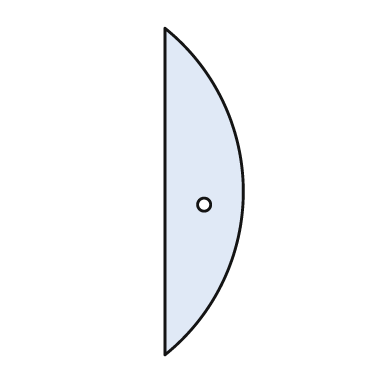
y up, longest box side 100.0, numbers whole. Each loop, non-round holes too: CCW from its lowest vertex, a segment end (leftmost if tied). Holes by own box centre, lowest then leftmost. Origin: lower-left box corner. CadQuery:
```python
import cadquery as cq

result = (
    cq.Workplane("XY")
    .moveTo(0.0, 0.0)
    .threePointArc((24.0, 50.0), (0.0, 100.0))
    .close()
    .moveTo(12.0, 46.0)
    .circle(2.0)
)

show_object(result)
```